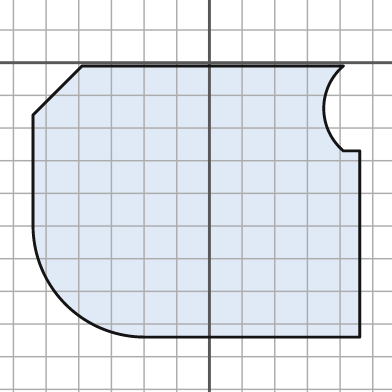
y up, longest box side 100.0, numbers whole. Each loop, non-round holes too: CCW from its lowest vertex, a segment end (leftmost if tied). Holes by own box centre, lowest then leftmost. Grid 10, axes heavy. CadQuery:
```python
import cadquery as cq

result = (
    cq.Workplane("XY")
    .moveTo(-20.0, -84.0)
    .lineTo(46.0, -84.0)
    .lineTo(46.0, -27.0)
    .lineTo(41.0, -27.0)
    .threePointArc((35.0, -14.0), (41.0, -1.0))
    .lineTo(-39.0, -1.0)
    .lineTo(-54.0, -16.0)
    .lineTo(-54.0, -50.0)
    .threePointArc((-44.0, -74.0), (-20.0, -84.0))
    .close()
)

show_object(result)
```